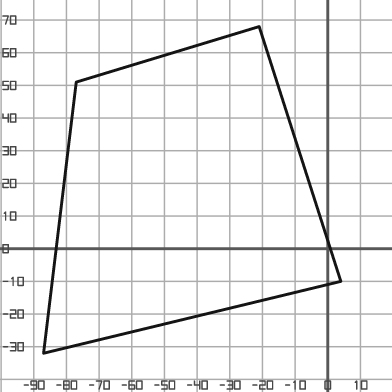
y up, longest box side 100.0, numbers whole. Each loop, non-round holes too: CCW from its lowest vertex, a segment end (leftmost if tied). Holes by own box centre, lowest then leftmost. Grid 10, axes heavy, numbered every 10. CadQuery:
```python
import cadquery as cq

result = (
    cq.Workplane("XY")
    .moveTo(-87.0, -32.0)
    .lineTo(4.0, -10.0)
    .lineTo(-21.0, 68.0)
    .lineTo(-77.0, 51.0)
    .close()
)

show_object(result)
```